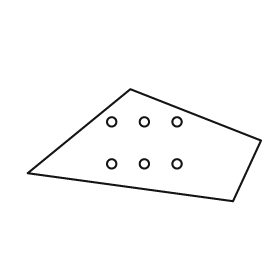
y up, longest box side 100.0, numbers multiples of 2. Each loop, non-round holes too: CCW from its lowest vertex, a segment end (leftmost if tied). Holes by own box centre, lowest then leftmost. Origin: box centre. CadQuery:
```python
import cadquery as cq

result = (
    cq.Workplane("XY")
    .moveTo(38.0, -24.0)
    .lineTo(50.0, 2.0)
    .lineTo(-6.0, 24.0)
    .lineTo(-50.0, -12.0)
    .close()
    .moveTo(-14.0, -8.0)
    .circle(2.0)
    .moveTo(0.0, -8.0)
    .circle(2.0)
    .moveTo(14.0, -8.0)
    .circle(2.0)
    .moveTo(-14.0, 10.0)
    .circle(2.0)
    .moveTo(0.0, 10.0)
    .circle(2.0)
    .moveTo(14.0, 10.0)
    .circle(2.0)
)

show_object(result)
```